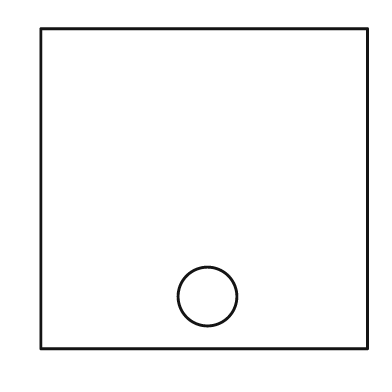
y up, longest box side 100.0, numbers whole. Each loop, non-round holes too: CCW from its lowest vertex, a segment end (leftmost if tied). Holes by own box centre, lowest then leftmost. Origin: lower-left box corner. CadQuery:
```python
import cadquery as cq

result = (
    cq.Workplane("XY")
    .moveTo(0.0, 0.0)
    .lineTo(100.0, 0.0)
    .lineTo(100.0, 98.0)
    .lineTo(0.0, 98.0)
    .close()
    .moveTo(51.0, 16.0)
    .circle(9.0)
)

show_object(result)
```